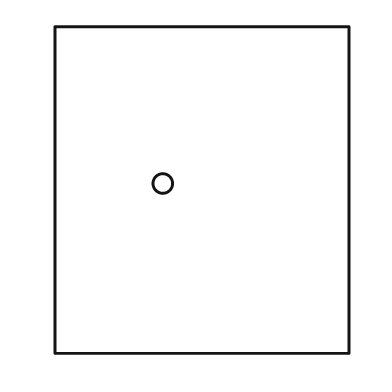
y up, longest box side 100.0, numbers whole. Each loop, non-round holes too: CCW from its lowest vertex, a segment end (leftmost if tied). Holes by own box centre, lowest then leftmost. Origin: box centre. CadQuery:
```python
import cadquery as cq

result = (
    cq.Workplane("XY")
    .moveTo(-45.0, -50.0)
    .lineTo(45.0, -50.0)
    .lineTo(45.0, 50.0)
    .lineTo(-45.0, 50.0)
    .close()
    .moveTo(-12.0, 2.0)
    .circle(3.0)
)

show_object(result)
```